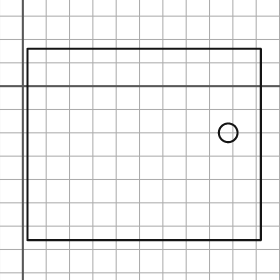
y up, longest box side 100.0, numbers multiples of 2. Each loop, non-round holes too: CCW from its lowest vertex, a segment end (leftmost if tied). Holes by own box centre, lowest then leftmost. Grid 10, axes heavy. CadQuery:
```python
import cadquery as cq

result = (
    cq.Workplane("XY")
    .moveTo(2.0, -66.0)
    .lineTo(102.0, -66.0)
    .lineTo(102.0, 16.0)
    .lineTo(2.0, 16.0)
    .close()
    .moveTo(88.0, -20.0)
    .circle(4.0)
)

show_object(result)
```